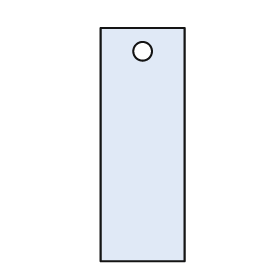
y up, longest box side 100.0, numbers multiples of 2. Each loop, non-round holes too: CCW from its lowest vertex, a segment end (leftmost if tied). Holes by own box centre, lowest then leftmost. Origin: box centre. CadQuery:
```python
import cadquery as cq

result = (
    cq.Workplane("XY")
    .moveTo(-18.0, -50.0)
    .lineTo(18.0, -50.0)
    .lineTo(18.0, 50.0)
    .lineTo(-18.0, 50.0)
    .close()
    .moveTo(0.0, 40.0)
    .circle(4.0)
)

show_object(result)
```